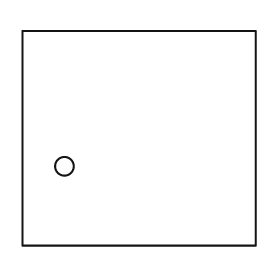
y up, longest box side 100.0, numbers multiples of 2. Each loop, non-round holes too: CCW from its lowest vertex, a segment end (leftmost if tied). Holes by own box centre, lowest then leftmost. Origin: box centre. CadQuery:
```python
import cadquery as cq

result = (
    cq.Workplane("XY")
    .moveTo(-50.0, -46.0)
    .lineTo(50.0, -46.0)
    .lineTo(50.0, 46.0)
    .lineTo(-50.0, 46.0)
    .close()
    .moveTo(-32.0, -12.0)
    .circle(4.0)
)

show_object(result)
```